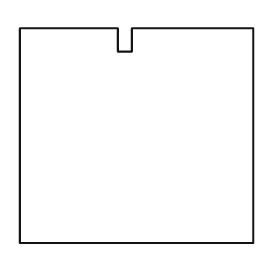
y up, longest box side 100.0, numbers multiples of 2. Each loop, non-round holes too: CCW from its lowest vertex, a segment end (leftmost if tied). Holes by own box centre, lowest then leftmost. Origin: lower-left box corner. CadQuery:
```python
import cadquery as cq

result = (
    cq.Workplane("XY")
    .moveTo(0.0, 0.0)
    .lineTo(100.0, 0.0)
    .lineTo(100.0, 92.0)
    .lineTo(48.0, 92.0)
    .lineTo(48.0, 82.0)
    .lineTo(42.0, 82.0)
    .lineTo(42.0, 92.0)
    .lineTo(0.0, 92.0)
    .close()
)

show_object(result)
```